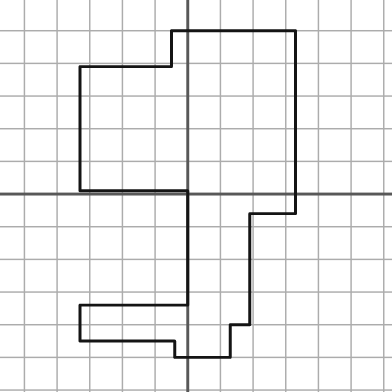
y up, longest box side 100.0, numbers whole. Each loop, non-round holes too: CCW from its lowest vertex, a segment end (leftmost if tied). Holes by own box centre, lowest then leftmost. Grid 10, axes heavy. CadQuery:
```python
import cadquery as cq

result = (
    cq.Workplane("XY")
    .moveTo(-4.0, -50.0)
    .lineTo(13.0, -50.0)
    .lineTo(13.0, -40.0)
    .lineTo(19.0, -40.0)
    .lineTo(19.0, -6.0)
    .lineTo(33.0, -6.0)
    .lineTo(33.0, 50.0)
    .lineTo(-5.0, 50.0)
    .lineTo(-5.0, 39.0)
    .lineTo(-33.0, 39.0)
    .lineTo(-33.0, 1.0)
    .lineTo(0.0, 1.0)
    .lineTo(0.0, -34.0)
    .lineTo(-33.0, -34.0)
    .lineTo(-33.0, -45.0)
    .lineTo(-4.0, -45.0)
    .close()
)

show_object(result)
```